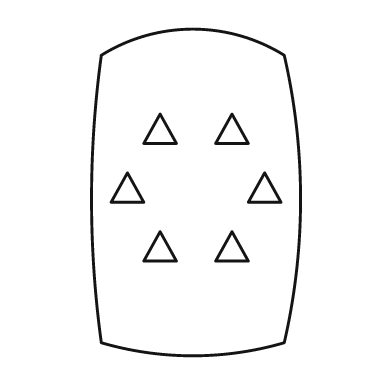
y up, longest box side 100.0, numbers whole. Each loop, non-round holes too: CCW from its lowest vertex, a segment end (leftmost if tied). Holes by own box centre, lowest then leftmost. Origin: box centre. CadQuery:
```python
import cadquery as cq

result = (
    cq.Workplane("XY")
    .moveTo(-29.0, -46.0)
    .threePointArc((-1.0, -50.0), (27.0, -46.0))
    .threePointArc((32.0, -2.0), (27.0, 42.0))
    .threePointArc((-1.0, 50.0), (-29.0, 42.0))
    .threePointArc((-32.0, -2.0), (-29.0, -46.0))
    .close()
    .moveTo(-16.0, -21.0)
    .lineTo(-6.0, -21.0)
    .lineTo(-11.0, -12.0)
    .close()
    .moveTo(6.0, -21.0)
    .lineTo(16.0, -21.0)
    .lineTo(11.0, -12.0)
    .close()
    .moveTo(-26.0, -3.0)
    .lineTo(-16.0, -3.0)
    .lineTo(-21.0, 6.0)
    .close()
    .moveTo(16.0, -3.0)
    .lineTo(26.0, -3.0)
    .lineTo(21.0, 6.0)
    .close()
    .moveTo(-16.0, 15.0)
    .lineTo(-6.0, 15.0)
    .lineTo(-11.0, 24.0)
    .close()
    .moveTo(6.0, 15.0)
    .lineTo(16.0, 15.0)
    .lineTo(11.0, 24.0)
    .close()
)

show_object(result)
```